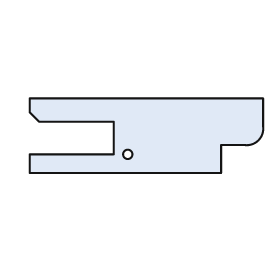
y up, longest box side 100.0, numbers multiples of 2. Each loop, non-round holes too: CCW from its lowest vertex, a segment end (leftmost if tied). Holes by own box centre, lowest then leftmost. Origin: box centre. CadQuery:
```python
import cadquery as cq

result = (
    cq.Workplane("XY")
    .moveTo(-50.0, -16.0)
    .lineTo(32.0, -16.0)
    .lineTo(32.0, -4.0)
    .lineTo(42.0, -4.0)
    .threePointArc((48.0, -2.0), (50.0, 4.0))
    .lineTo(50.0, 16.0)
    .lineTo(-50.0, 16.0)
    .lineTo(-50.0, 10.0)
    .lineTo(-46.0, 6.0)
    .lineTo(-14.0, 6.0)
    .lineTo(-14.0, -8.0)
    .lineTo(-50.0, -8.0)
    .close()
    .moveTo(-8.0, -8.0)
    .circle(2.0)
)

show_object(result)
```